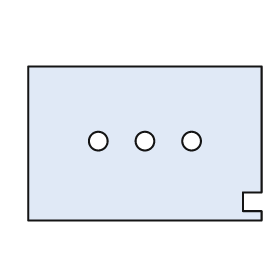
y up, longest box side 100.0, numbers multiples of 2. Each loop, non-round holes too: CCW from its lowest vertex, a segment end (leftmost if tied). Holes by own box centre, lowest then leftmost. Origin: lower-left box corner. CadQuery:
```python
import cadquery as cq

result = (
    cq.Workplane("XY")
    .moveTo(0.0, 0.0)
    .lineTo(100.0, 0.0)
    .lineTo(100.0, 4.0)
    .lineTo(92.0, 4.0)
    .lineTo(92.0, 12.0)
    .lineTo(100.0, 12.0)
    .lineTo(100.0, 66.0)
    .lineTo(0.0, 66.0)
    .close()
    .moveTo(30.0, 34.0)
    .circle(4.0)
    .moveTo(50.0, 34.0)
    .circle(4.0)
    .moveTo(70.0, 34.0)
    .circle(4.0)
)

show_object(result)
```